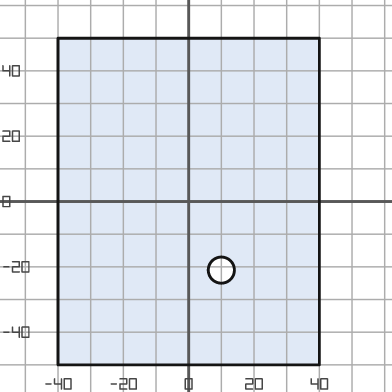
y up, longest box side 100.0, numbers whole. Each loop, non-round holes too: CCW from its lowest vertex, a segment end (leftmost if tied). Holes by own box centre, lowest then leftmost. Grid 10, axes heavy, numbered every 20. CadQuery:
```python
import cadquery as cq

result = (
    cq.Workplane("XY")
    .moveTo(-40.0, -50.0)
    .lineTo(40.0, -50.0)
    .lineTo(40.0, 50.0)
    .lineTo(-40.0, 50.0)
    .close()
    .moveTo(10.0, -21.0)
    .circle(4.0)
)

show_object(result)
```